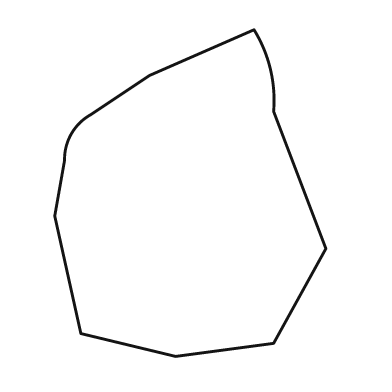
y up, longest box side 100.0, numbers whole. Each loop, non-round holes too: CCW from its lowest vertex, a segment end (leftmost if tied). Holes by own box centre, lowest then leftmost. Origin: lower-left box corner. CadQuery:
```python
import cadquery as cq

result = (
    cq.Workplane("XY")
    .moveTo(37.0, 0.0)
    .lineTo(67.0, 4.0)
    .lineTo(83.0, 33.0)
    .lineTo(67.0, 75.0)
    .threePointArc((66.0, 88.0), (61.0, 100.0))
    .lineTo(29.0, 86.0)
    .lineTo(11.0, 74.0)
    .threePointArc((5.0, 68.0), (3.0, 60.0))
    .lineTo(0.0, 43.0)
    .lineTo(8.0, 7.0)
    .close()
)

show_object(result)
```